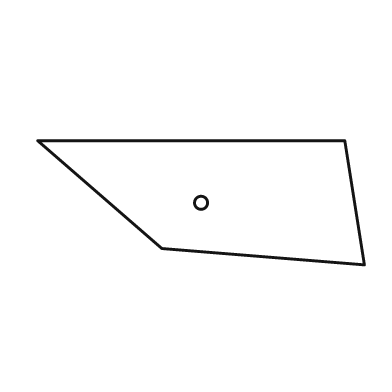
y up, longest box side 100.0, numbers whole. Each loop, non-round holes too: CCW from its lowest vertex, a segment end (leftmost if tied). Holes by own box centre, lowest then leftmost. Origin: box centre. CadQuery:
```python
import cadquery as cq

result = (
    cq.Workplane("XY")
    .moveTo(50.0, -19.0)
    .lineTo(44.0, 19.0)
    .lineTo(-50.0, 19.0)
    .lineTo(-12.0, -14.0)
    .close()
    .moveTo(0.0, 0.0)
    .circle(2.0)
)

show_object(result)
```